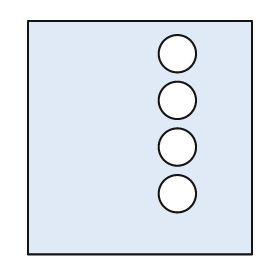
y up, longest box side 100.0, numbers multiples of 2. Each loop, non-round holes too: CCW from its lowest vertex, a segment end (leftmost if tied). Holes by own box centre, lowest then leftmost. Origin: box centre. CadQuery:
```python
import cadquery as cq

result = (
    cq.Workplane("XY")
    .moveTo(-48.0, -50.0)
    .lineTo(48.0, -50.0)
    .lineTo(48.0, 50.0)
    .lineTo(-48.0, 50.0)
    .close()
    .moveTo(16.0, -24.0)
    .circle(8.0)
    .moveTo(16.0, -4.0)
    .circle(8.0)
    .moveTo(16.0, 16.0)
    .circle(8.0)
    .moveTo(16.0, 36.0)
    .circle(8.0)
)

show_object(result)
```